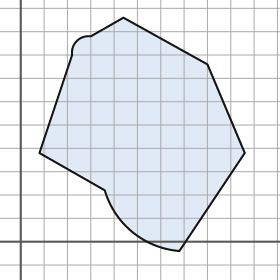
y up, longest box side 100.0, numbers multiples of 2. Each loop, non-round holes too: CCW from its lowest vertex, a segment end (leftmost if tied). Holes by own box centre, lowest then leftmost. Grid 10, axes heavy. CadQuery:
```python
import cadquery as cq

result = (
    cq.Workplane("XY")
    .moveTo(68.0, -4.0)
    .lineTo(96.0, 38.0)
    .lineTo(80.0, 76.0)
    .lineTo(44.0, 96.0)
    .lineTo(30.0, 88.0)
    .threePointArc((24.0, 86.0), (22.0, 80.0))
    .lineTo(8.0, 38.0)
    .lineTo(36.0, 22.0)
    .threePointArc((48.0, 4.0), (68.0, -4.0))
    .close()
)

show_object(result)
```